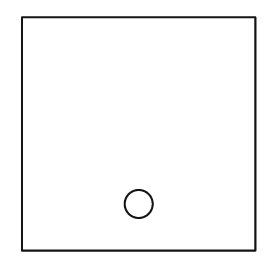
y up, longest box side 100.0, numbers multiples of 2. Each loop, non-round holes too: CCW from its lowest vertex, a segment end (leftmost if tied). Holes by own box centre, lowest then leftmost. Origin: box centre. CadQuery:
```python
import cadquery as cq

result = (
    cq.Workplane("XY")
    .moveTo(-50.0, -50.0)
    .lineTo(50.0, -50.0)
    .lineTo(50.0, 50.0)
    .lineTo(-50.0, 50.0)
    .close()
    .moveTo(0.0, -30.0)
    .circle(6.0)
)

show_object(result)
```